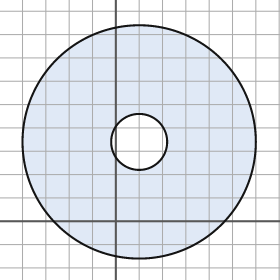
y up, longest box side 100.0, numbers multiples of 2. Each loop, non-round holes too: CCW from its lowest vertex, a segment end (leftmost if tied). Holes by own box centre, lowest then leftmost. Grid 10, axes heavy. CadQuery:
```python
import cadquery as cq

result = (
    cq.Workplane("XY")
    .moveTo(10.0, 34.0)
    .circle(50.0)
    .moveTo(10.0, 34.0)
    .circle(12.0)
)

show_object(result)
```